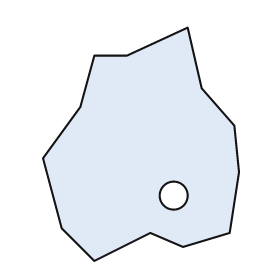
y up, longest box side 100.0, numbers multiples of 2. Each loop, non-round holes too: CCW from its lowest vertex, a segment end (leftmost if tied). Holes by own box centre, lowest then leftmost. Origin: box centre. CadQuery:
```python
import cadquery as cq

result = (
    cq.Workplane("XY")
    .moveTo(-20.0, -50.0)
    .lineTo(4.0, -38.0)
    .lineTo(18.0, -44.0)
    .lineTo(38.0, -38.0)
    .lineTo(42.0, -12.0)
    .lineTo(40.0, 8.0)
    .lineTo(26.0, 24.0)
    .lineTo(20.0, 50.0)
    .lineTo(-6.0, 38.0)
    .lineTo(-20.0, 38.0)
    .lineTo(-26.0, 16.0)
    .lineTo(-42.0, -6.0)
    .lineTo(-34.0, -36.0)
    .close()
    .moveTo(14.0, -22.0)
    .circle(6.0)
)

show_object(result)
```